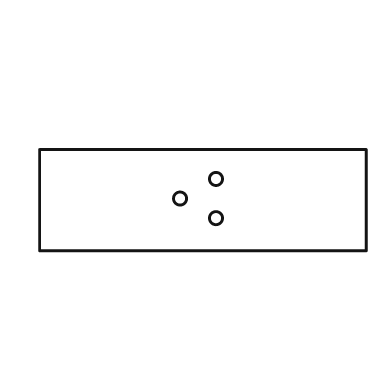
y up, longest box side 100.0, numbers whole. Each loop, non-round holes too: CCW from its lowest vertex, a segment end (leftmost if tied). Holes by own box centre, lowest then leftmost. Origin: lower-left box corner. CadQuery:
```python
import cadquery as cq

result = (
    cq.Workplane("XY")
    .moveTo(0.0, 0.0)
    .lineTo(100.0, 0.0)
    .lineTo(100.0, 31.0)
    .lineTo(0.0, 31.0)
    .close()
    .moveTo(54.0, 10.0)
    .circle(2.0)
    .moveTo(43.0, 16.0)
    .circle(2.0)
    .moveTo(54.0, 22.0)
    .circle(2.0)
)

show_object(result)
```